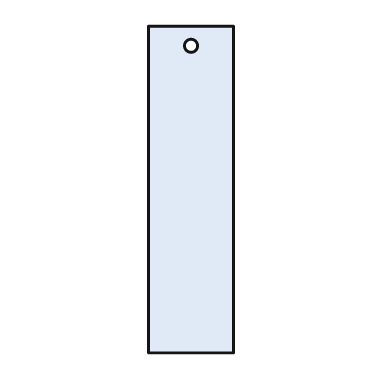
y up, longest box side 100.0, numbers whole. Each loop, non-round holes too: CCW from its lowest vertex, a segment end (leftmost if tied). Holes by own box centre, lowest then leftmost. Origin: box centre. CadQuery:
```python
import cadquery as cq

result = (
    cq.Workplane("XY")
    .moveTo(-13.0, -50.0)
    .lineTo(13.0, -50.0)
    .lineTo(13.0, 50.0)
    .lineTo(-13.0, 50.0)
    .close()
    .moveTo(0.0, 44.0)
    .circle(2.0)
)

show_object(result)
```